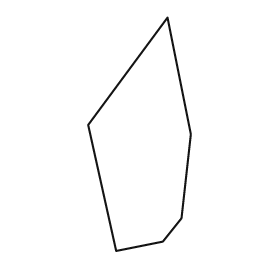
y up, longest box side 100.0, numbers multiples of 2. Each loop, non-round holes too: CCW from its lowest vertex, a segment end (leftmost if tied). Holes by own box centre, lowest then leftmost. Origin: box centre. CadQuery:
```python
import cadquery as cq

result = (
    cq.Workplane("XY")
    .moveTo(-10.0, -50.0)
    .lineTo(10.0, -46.0)
    .lineTo(18.0, -36.0)
    .lineTo(22.0, 0.0)
    .lineTo(12.0, 50.0)
    .lineTo(-22.0, 4.0)
    .close()
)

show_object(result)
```